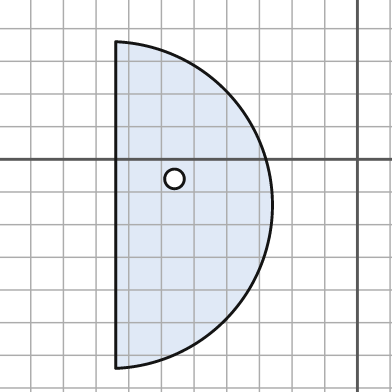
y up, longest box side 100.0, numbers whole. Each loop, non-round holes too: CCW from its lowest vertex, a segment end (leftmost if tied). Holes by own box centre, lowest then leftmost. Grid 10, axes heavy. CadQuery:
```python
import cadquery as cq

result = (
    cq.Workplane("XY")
    .moveTo(-74.0, -64.0)
    .threePointArc((-26.0, -14.0), (-74.0, 36.0))
    .close()
    .moveTo(-56.0, -6.0)
    .circle(3.0)
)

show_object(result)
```